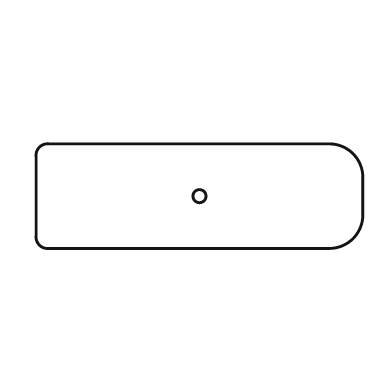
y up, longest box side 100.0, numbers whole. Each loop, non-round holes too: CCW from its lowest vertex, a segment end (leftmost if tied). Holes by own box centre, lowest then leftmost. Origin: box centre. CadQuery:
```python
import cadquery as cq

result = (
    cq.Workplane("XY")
    .moveTo(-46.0, -16.0)
    .lineTo(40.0, -16.0)
    .threePointArc((47.0, -13.0), (50.0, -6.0))
    .lineTo(50.0, 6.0)
    .threePointArc((47.0, 13.0), (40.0, 16.0))
    .lineTo(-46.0, 16.0)
    .threePointArc((-49.0, 15.0), (-50.0, 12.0))
    .lineTo(-50.0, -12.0)
    .threePointArc((-49.0, -15.0), (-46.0, -16.0))
    .close()
    .moveTo(0.0, 0.0)
    .circle(2.0)
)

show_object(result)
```